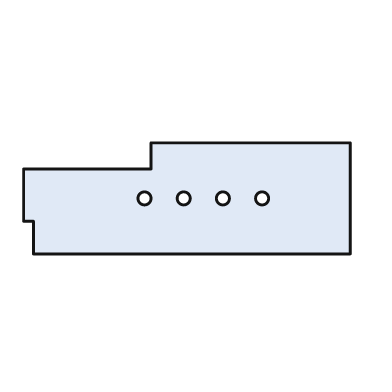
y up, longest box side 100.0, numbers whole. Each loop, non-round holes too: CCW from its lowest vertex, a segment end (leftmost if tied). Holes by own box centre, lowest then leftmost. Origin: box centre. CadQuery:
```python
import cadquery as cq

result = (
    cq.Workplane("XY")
    .moveTo(-47.0, -17.0)
    .lineTo(50.0, -17.0)
    .lineTo(50.0, 17.0)
    .lineTo(-11.0, 17.0)
    .lineTo(-11.0, 9.0)
    .lineTo(-50.0, 9.0)
    .lineTo(-50.0, -7.0)
    .lineTo(-47.0, -7.0)
    .close()
    .moveTo(-13.0, 0.0)
    .circle(2.0)
    .moveTo(-1.0, 0.0)
    .circle(2.0)
    .moveTo(11.0, 0.0)
    .circle(2.0)
    .moveTo(23.0, 0.0)
    .circle(2.0)
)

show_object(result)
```